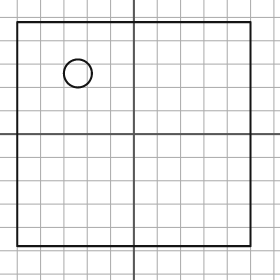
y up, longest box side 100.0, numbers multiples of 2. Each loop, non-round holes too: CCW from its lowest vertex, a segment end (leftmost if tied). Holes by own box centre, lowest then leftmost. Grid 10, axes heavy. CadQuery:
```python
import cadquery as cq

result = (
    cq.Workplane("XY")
    .moveTo(-50.0, -48.0)
    .lineTo(50.0, -48.0)
    .lineTo(50.0, 48.0)
    .lineTo(-50.0, 48.0)
    .close()
    .moveTo(-24.0, 26.0)
    .circle(6.0)
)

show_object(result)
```